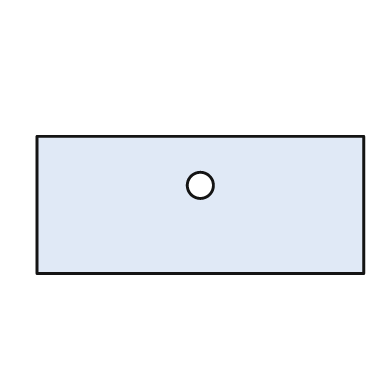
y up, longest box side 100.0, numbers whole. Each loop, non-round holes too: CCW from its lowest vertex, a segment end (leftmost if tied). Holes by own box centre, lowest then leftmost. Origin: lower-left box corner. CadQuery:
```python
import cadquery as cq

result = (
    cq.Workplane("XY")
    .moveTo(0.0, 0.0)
    .lineTo(100.0, 0.0)
    .lineTo(100.0, 42.0)
    .lineTo(0.0, 42.0)
    .close()
    .moveTo(50.0, 27.0)
    .circle(4.0)
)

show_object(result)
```